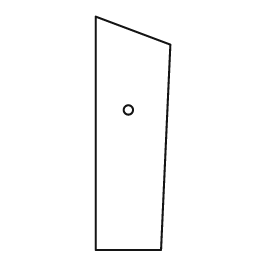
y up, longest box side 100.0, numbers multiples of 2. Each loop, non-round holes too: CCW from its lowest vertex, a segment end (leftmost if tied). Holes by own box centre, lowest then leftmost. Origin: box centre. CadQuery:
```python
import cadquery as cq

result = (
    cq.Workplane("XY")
    .moveTo(-16.0, -50.0)
    .lineTo(12.0, -50.0)
    .lineTo(16.0, 38.0)
    .lineTo(-16.0, 50.0)
    .close()
    .moveTo(-2.0, 10.0)
    .circle(2.0)
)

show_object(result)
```